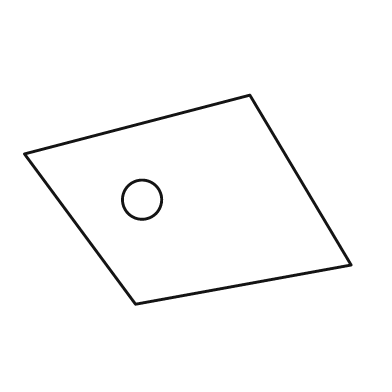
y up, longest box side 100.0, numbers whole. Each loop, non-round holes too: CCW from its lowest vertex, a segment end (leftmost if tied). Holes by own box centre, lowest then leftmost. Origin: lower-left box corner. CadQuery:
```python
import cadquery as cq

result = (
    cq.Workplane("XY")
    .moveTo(34.0, 0.0)
    .lineTo(100.0, 12.0)
    .lineTo(69.0, 64.0)
    .lineTo(0.0, 46.0)
    .close()
    .moveTo(36.0, 32.0)
    .circle(6.0)
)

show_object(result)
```